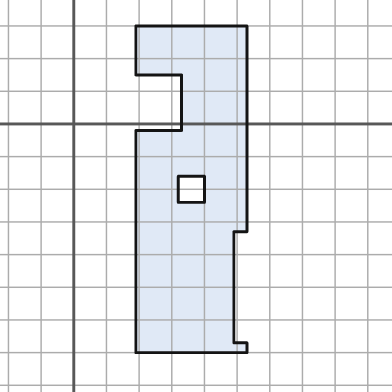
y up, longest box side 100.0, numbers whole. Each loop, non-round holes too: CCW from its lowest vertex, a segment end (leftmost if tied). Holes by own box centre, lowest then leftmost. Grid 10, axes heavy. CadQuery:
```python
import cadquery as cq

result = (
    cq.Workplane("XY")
    .moveTo(19.0, -70.0)
    .lineTo(53.0, -70.0)
    .lineTo(53.0, -67.0)
    .lineTo(49.0, -67.0)
    .lineTo(49.0, -33.0)
    .lineTo(53.0, -33.0)
    .lineTo(53.0, 30.0)
    .lineTo(19.0, 30.0)
    .lineTo(19.0, 15.0)
    .lineTo(33.0, 15.0)
    .lineTo(33.0, -2.0)
    .lineTo(19.0, -2.0)
    .close()
    .moveTo(32.0, -24.0)
    .lineTo(40.0, -24.0)
    .lineTo(40.0, -16.0)
    .lineTo(32.0, -16.0)
    .close()
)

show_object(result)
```